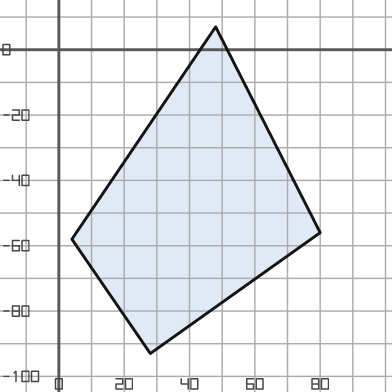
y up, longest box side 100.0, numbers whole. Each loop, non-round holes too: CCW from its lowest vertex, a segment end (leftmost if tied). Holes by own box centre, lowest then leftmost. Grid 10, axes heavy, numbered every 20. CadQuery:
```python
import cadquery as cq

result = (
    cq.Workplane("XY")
    .moveTo(28.0, -93.0)
    .lineTo(80.0, -56.0)
    .lineTo(48.0, 7.0)
    .lineTo(4.0, -58.0)
    .close()
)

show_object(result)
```